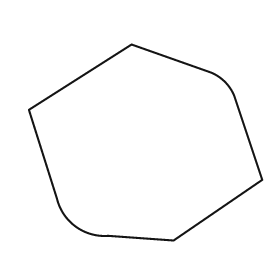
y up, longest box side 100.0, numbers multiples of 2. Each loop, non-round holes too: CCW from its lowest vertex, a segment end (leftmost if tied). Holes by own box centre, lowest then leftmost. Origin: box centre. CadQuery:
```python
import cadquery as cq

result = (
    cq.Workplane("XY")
    .moveTo(12.0, -42.0)
    .lineTo(50.0, -16.0)
    .lineTo(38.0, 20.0)
    .threePointArc((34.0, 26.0), (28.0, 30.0))
    .lineTo(-6.0, 42.0)
    .lineTo(-50.0, 14.0)
    .lineTo(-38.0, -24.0)
    .threePointArc((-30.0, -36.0), (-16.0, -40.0))
    .close()
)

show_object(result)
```